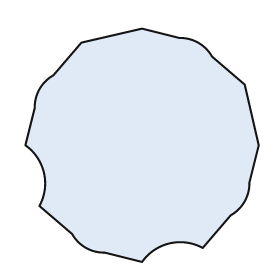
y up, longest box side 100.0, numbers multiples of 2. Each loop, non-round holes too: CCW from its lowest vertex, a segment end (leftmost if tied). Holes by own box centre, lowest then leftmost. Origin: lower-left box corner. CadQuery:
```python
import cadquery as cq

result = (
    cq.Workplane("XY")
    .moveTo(50.0, 0.0)
    .threePointArc((62.0, 8.0), (76.0, 6.0))
    .lineTo(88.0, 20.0)
    .threePointArc((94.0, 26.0), (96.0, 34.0))
    .lineTo(100.0, 50.0)
    .lineTo(94.0, 76.0)
    .lineTo(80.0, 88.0)
    .threePointArc((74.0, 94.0), (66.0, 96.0))
    .lineTo(50.0, 100.0)
    .lineTo(24.0, 94.0)
    .lineTo(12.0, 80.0)
    .threePointArc((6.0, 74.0), (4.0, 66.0))
    .lineTo(0.0, 50.0)
    .threePointArc((8.0, 38.0), (6.0, 24.0))
    .lineTo(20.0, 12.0)
    .threePointArc((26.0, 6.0), (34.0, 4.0))
    .close()
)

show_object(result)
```